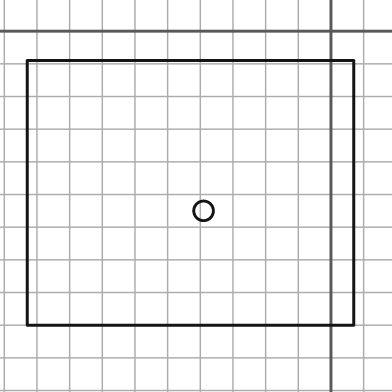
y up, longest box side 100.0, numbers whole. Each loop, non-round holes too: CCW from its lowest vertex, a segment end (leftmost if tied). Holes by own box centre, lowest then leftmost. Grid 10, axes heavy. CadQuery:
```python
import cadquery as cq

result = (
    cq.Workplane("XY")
    .moveTo(-93.0, -90.0)
    .lineTo(7.0, -90.0)
    .lineTo(7.0, -9.0)
    .lineTo(-93.0, -9.0)
    .close()
    .moveTo(-39.0, -55.0)
    .circle(3.0)
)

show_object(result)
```